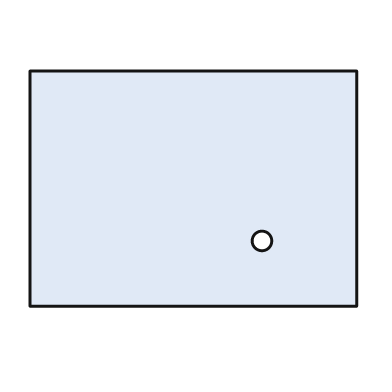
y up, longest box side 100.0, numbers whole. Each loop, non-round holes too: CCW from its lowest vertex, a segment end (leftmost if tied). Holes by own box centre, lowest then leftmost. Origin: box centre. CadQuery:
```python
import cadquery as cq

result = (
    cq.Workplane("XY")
    .moveTo(-50.0, -36.0)
    .lineTo(50.0, -36.0)
    .lineTo(50.0, 36.0)
    .lineTo(-50.0, 36.0)
    .close()
    .moveTo(21.0, -16.0)
    .circle(3.0)
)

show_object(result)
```